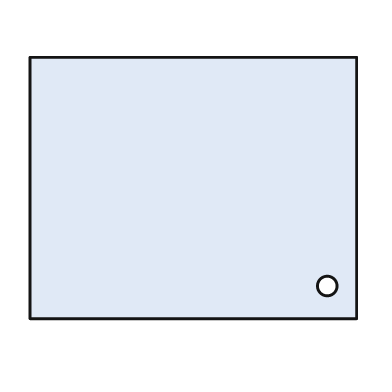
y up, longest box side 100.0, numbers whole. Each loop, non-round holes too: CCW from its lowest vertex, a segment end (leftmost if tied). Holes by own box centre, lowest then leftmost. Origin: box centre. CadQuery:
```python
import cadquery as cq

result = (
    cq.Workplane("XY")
    .moveTo(-50.0, -40.0)
    .lineTo(50.0, -40.0)
    .lineTo(50.0, 40.0)
    .lineTo(-50.0, 40.0)
    .close()
    .moveTo(41.0, -30.0)
    .circle(3.0)
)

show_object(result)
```